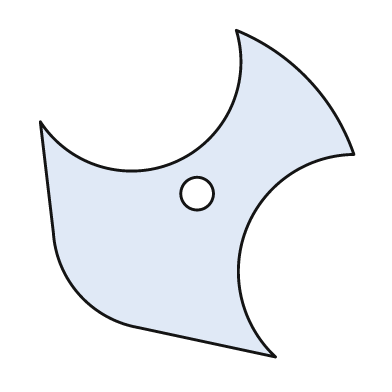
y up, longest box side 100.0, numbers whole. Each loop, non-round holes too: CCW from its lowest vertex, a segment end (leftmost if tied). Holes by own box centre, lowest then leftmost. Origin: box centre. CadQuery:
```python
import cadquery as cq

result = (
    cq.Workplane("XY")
    .moveTo(24.0, -50.0)
    .threePointArc((15.0, -11.0), (48.0, 12.0))
    .threePointArc((34.0, 35.0), (12.0, 50.0))
    .threePointArc((-6.0, 10.0), (-48.0, 22.0))
    .lineTo(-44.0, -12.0)
    .threePointArc((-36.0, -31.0), (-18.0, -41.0))
    .close()
    .moveTo(0.0, 0.0)
    .circle(5.0)
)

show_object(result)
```